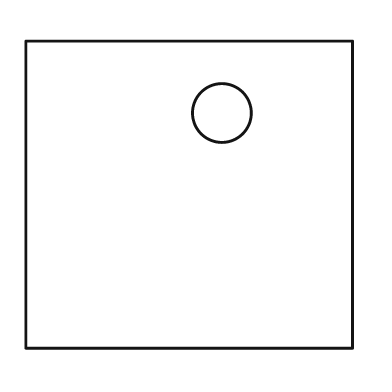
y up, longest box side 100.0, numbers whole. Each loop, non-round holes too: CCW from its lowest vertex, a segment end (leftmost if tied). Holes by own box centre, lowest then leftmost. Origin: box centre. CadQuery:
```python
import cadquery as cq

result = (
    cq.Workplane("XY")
    .moveTo(-50.0, -47.0)
    .lineTo(50.0, -47.0)
    .lineTo(50.0, 47.0)
    .lineTo(-50.0, 47.0)
    .close()
    .moveTo(10.0, 25.0)
    .circle(9.0)
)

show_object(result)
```